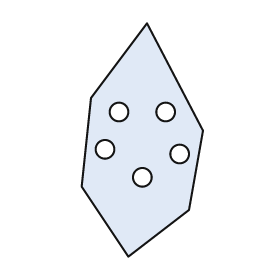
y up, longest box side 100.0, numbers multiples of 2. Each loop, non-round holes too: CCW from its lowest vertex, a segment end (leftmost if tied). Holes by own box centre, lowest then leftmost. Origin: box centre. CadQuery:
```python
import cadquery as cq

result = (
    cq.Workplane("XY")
    .moveTo(-6.0, -50.0)
    .lineTo(20.0, -30.0)
    .lineTo(26.0, 4.0)
    .lineTo(2.0, 50.0)
    .lineTo(-22.0, 18.0)
    .lineTo(-26.0, -20.0)
    .close()
    .moveTo(0.0, -16.0)
    .circle(4.0)
    .moveTo(16.0, -6.0)
    .circle(4.0)
    .moveTo(-16.0, -4.0)
    .circle(4.0)
    .moveTo(-10.0, 12.0)
    .circle(4.0)
    .moveTo(10.0, 12.0)
    .circle(4.0)
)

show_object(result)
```